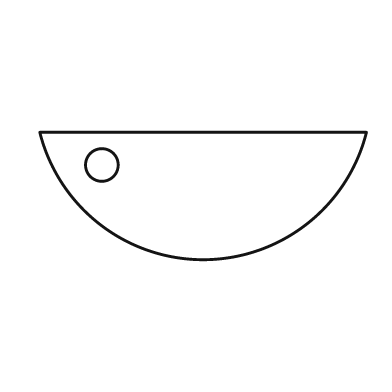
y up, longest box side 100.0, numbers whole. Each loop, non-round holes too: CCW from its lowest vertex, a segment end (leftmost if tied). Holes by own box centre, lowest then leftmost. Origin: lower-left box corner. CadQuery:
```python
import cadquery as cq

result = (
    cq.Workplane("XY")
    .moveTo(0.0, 39.0)
    .threePointArc((50.0, 0.0), (100.0, 39.0))
    .close()
    .moveTo(19.0, 29.0)
    .circle(5.0)
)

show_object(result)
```